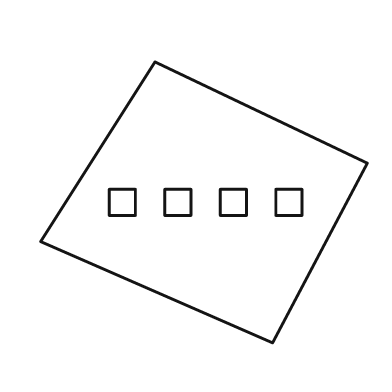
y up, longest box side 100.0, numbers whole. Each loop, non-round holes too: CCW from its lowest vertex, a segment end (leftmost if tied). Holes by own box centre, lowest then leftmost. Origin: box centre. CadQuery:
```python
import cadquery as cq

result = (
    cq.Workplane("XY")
    .moveTo(21.0, -43.0)
    .lineTo(50.0, 12.0)
    .lineTo(-15.0, 43.0)
    .lineTo(-50.0, -12.0)
    .close()
    .moveTo(-29.0, -4.0)
    .lineTo(-21.0, -4.0)
    .lineTo(-21.0, 4.0)
    .lineTo(-29.0, 4.0)
    .close()
    .moveTo(-12.0, -4.0)
    .lineTo(-4.0, -4.0)
    .lineTo(-4.0, 4.0)
    .lineTo(-12.0, 4.0)
    .close()
    .moveTo(5.0, -4.0)
    .lineTo(13.0, -4.0)
    .lineTo(13.0, 4.0)
    .lineTo(5.0, 4.0)
    .close()
    .moveTo(22.0, -4.0)
    .lineTo(30.0, -4.0)
    .lineTo(30.0, 4.0)
    .lineTo(22.0, 4.0)
    .close()
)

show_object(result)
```